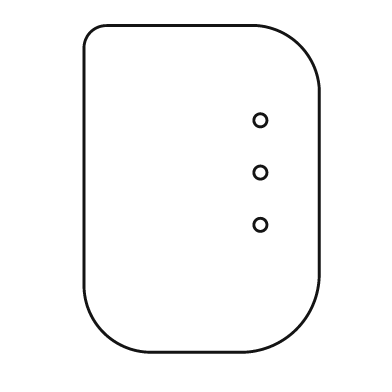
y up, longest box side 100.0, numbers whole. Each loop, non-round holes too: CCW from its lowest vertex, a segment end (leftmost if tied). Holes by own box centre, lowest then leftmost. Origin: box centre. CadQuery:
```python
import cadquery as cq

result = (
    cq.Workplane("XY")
    .moveTo(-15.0, -50.0)
    .lineTo(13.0, -50.0)
    .threePointArc((29.0, -43.0), (36.0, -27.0))
    .lineTo(36.0, 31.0)
    .threePointArc((30.0, 44.0), (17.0, 50.0))
    .lineTo(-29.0, 50.0)
    .threePointArc((-34.0, 48.0), (-36.0, 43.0))
    .lineTo(-36.0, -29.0)
    .threePointArc((-30.0, -44.0), (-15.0, -50.0))
    .close()
    .moveTo(18.0, -11.0)
    .circle(2.0)
    .moveTo(18.0, 5.0)
    .circle(2.0)
    .moveTo(18.0, 21.0)
    .circle(2.0)
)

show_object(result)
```